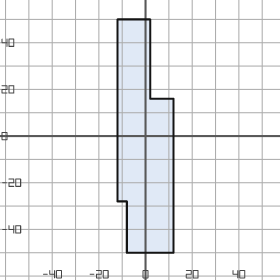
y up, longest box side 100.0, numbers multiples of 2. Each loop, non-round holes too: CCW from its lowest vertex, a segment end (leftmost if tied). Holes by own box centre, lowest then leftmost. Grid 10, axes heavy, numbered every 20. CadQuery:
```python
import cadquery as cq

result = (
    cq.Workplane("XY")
    .moveTo(-8.0, -50.0)
    .lineTo(12.0, -50.0)
    .lineTo(12.0, 16.0)
    .lineTo(2.0, 16.0)
    .lineTo(2.0, 50.0)
    .lineTo(-12.0, 50.0)
    .lineTo(-12.0, -28.0)
    .lineTo(-8.0, -28.0)
    .close()
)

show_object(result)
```